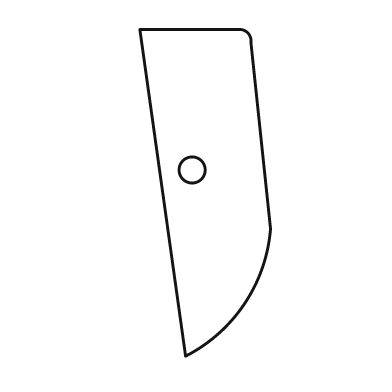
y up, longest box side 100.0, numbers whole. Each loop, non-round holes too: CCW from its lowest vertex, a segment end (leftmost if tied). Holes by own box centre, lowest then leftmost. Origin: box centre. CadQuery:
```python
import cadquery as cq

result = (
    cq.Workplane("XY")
    .moveTo(-6.0, -50.0)
    .threePointArc((12.0, -34.0), (20.0, -11.0))
    .lineTo(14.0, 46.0)
    .threePointArc((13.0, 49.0), (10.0, 50.0))
    .lineTo(-20.0, 50.0)
    .close()
    .moveTo(-4.0, 7.0)
    .circle(4.0)
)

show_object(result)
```